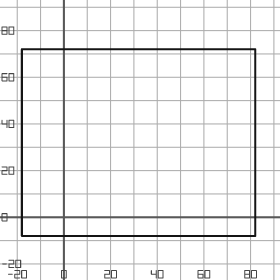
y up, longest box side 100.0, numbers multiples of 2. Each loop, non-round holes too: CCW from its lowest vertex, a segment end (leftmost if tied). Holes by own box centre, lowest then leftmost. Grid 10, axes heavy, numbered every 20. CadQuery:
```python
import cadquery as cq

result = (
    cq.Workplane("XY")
    .moveTo(-18.0, -8.0)
    .lineTo(82.0, -8.0)
    .lineTo(82.0, 72.0)
    .lineTo(-18.0, 72.0)
    .close()
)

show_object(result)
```